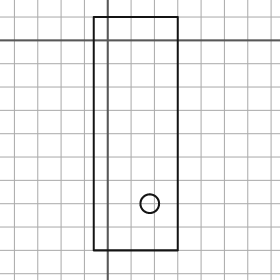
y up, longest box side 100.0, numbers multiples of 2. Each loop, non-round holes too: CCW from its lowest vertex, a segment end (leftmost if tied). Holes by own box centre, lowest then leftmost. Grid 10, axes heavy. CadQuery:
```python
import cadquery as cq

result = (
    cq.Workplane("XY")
    .moveTo(-6.0, -90.0)
    .lineTo(30.0, -90.0)
    .lineTo(30.0, 10.0)
    .lineTo(-6.0, 10.0)
    .close()
    .moveTo(18.0, -70.0)
    .circle(4.0)
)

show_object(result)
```